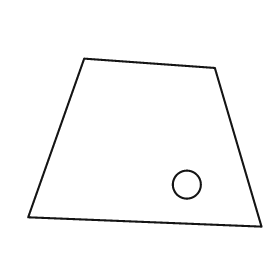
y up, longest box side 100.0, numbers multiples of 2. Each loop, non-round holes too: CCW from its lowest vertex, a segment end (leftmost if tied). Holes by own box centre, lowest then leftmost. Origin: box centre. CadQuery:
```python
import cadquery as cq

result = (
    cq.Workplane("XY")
    .moveTo(50.0, -36.0)
    .lineTo(30.0, 32.0)
    .lineTo(-26.0, 36.0)
    .lineTo(-50.0, -32.0)
    .close()
    .moveTo(18.0, -18.0)
    .circle(6.0)
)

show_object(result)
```